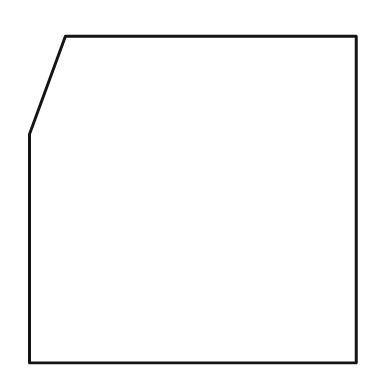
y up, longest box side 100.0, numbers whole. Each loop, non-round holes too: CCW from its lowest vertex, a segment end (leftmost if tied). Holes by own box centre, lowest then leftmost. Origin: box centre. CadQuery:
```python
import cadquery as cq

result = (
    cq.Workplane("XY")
    .moveTo(-50.0, -50.0)
    .lineTo(50.0, -50.0)
    .lineTo(50.0, 50.0)
    .lineTo(-39.0, 50.0)
    .lineTo(-50.0, 20.0)
    .close()
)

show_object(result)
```